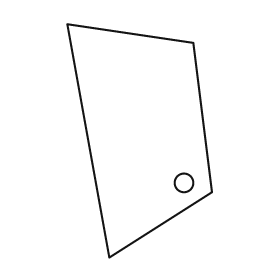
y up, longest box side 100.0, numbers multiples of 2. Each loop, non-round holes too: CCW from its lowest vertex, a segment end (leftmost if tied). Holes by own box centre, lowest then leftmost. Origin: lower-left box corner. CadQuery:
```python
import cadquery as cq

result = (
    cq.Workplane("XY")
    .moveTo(18.0, 0.0)
    .lineTo(62.0, 28.0)
    .lineTo(54.0, 92.0)
    .lineTo(0.0, 100.0)
    .close()
    .moveTo(50.0, 32.0)
    .circle(4.0)
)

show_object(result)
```